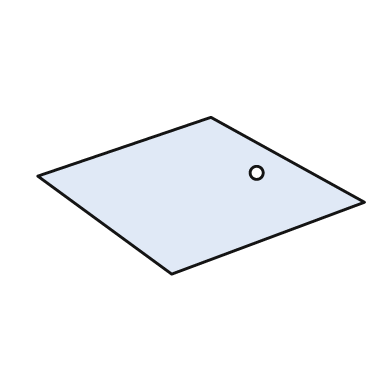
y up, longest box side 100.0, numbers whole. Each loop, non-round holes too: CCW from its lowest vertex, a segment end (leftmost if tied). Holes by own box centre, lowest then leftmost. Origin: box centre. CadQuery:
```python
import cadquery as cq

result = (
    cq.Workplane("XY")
    .moveTo(-9.0, -24.0)
    .lineTo(50.0, -2.0)
    .lineTo(3.0, 24.0)
    .lineTo(-50.0, 6.0)
    .close()
    .moveTo(17.0, 7.0)
    .circle(2.0)
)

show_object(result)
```